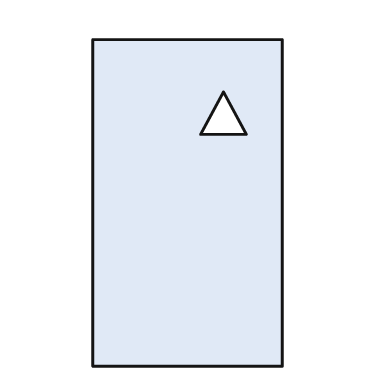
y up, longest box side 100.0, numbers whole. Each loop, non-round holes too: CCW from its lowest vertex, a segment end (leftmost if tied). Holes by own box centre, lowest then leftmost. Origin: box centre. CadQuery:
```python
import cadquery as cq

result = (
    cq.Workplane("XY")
    .moveTo(-29.0, -50.0)
    .lineTo(29.0, -50.0)
    .lineTo(29.0, 50.0)
    .lineTo(-29.0, 50.0)
    .close()
    .moveTo(4.0, 21.0)
    .lineTo(18.0, 21.0)
    .lineTo(11.0, 34.0)
    .close()
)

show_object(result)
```